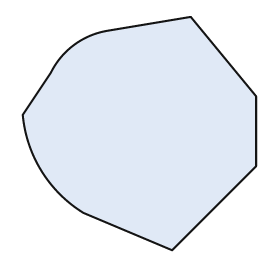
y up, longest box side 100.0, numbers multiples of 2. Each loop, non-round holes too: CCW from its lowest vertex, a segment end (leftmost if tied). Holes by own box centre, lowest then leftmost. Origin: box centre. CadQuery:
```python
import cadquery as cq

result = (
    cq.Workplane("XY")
    .moveTo(14.0, -50.0)
    .lineTo(50.0, -14.0)
    .lineTo(50.0, 16.0)
    .lineTo(22.0, 50.0)
    .lineTo(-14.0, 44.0)
    .threePointArc((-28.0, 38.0), (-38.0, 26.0))
    .lineTo(-50.0, 8.0)
    .threePointArc((-42.0, -16.0), (-24.0, -34.0))
    .close()
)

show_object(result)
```